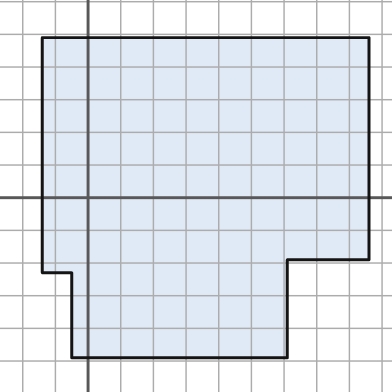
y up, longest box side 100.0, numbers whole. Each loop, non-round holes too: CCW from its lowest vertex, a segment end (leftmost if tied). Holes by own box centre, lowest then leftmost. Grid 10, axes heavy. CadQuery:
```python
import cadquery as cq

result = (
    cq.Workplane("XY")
    .moveTo(-5.0, -49.0)
    .lineTo(61.0, -49.0)
    .lineTo(61.0, -19.0)
    .lineTo(86.0, -19.0)
    .lineTo(86.0, 49.0)
    .lineTo(-14.0, 49.0)
    .lineTo(-14.0, -23.0)
    .lineTo(-5.0, -23.0)
    .close()
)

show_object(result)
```